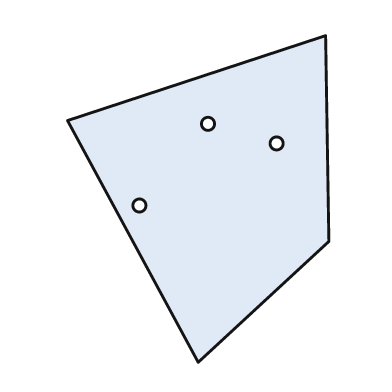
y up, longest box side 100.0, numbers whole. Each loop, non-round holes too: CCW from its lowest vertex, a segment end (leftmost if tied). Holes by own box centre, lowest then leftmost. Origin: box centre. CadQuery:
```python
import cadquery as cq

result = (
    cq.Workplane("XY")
    .moveTo(0.0, -50.0)
    .lineTo(40.0, -13.0)
    .lineTo(39.0, 50.0)
    .lineTo(-40.0, 24.0)
    .close()
    .moveTo(-18.0, -2.0)
    .circle(2.0)
    .moveTo(24.0, 17.0)
    .circle(2.0)
    .moveTo(3.0, 23.0)
    .circle(2.0)
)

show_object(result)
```